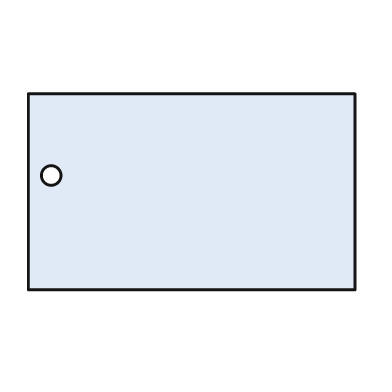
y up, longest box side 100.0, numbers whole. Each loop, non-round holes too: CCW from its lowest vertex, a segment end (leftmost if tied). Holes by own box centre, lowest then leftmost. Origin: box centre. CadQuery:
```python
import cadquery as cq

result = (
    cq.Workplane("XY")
    .moveTo(-50.0, -30.0)
    .lineTo(50.0, -30.0)
    .lineTo(50.0, 30.0)
    .lineTo(-50.0, 30.0)
    .close()
    .moveTo(-43.0, 5.0)
    .circle(3.0)
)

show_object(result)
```